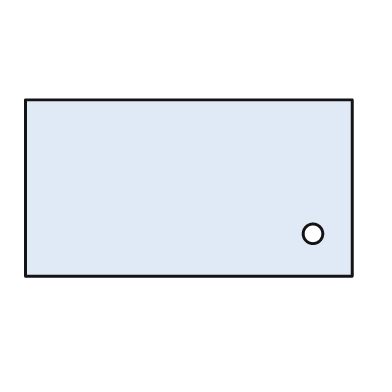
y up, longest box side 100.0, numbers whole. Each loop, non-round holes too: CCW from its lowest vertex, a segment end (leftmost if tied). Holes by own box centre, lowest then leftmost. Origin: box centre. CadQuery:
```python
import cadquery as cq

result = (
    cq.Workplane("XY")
    .moveTo(-50.0, -27.0)
    .lineTo(50.0, -27.0)
    .lineTo(50.0, 27.0)
    .lineTo(-50.0, 27.0)
    .close()
    .moveTo(38.0, -14.0)
    .circle(3.0)
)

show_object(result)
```